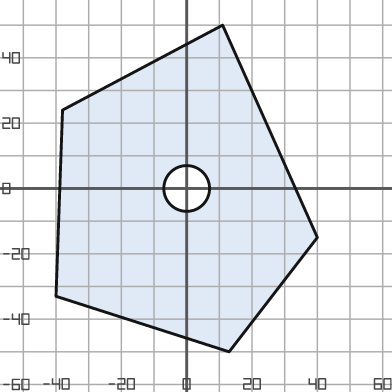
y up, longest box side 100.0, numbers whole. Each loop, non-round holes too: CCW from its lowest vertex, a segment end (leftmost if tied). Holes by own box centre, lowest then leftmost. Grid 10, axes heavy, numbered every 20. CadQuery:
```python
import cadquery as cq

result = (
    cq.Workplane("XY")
    .moveTo(13.0, -50.0)
    .lineTo(40.0, -15.0)
    .lineTo(11.0, 50.0)
    .lineTo(-38.0, 24.0)
    .lineTo(-40.0, -33.0)
    .close()
    .moveTo(0.0, 0.0)
    .circle(7.0)
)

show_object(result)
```